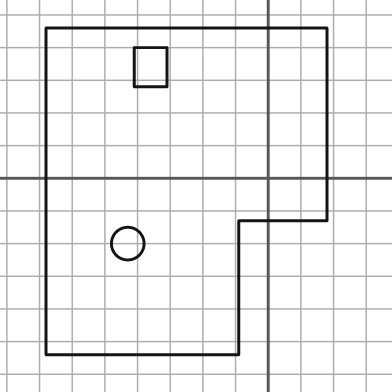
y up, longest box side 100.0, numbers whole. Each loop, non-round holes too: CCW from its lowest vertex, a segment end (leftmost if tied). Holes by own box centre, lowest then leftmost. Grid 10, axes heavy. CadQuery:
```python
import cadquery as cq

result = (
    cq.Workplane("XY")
    .moveTo(-68.0, -54.0)
    .lineTo(-9.0, -54.0)
    .lineTo(-9.0, -13.0)
    .lineTo(18.0, -13.0)
    .lineTo(18.0, 46.0)
    .lineTo(-68.0, 46.0)
    .close()
    .moveTo(-43.0, -20.0)
    .circle(5.0)
    .moveTo(-41.0, 28.0)
    .lineTo(-31.0, 28.0)
    .lineTo(-31.0, 40.0)
    .lineTo(-41.0, 40.0)
    .close()
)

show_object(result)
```